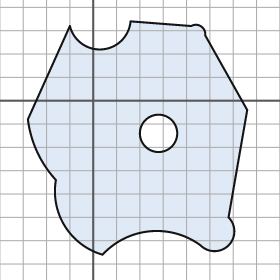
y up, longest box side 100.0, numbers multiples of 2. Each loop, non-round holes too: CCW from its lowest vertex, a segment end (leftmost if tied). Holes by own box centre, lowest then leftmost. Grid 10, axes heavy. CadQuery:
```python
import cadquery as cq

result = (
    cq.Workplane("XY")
    .moveTo(4.0, -66.0)
    .threePointArc((24.0, -56.0), (46.0, -62.0))
    .threePointArc((58.0, -62.0), (58.0, -50.0))
    .lineTo(66.0, -4.0)
    .lineTo(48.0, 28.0)
    .threePointArc((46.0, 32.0), (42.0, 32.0))
    .lineTo(16.0, 34.0)
    .threePointArc((4.0, 22.0), (-10.0, 32.0))
    .lineTo(-28.0, -8.0)
    .threePointArc((-24.0, -22.0), (-16.0, -34.0))
    .threePointArc((-12.0, -54.0), (4.0, -66.0))
    .close()
    .moveTo(28.0, -14.0)
    .circle(8.0)
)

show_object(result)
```